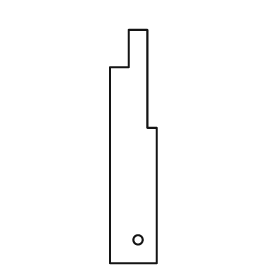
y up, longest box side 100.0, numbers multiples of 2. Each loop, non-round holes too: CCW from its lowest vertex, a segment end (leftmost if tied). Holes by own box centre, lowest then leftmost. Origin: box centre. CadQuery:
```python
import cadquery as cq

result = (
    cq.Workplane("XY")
    .moveTo(-10.0, -50.0)
    .lineTo(10.0, -50.0)
    .lineTo(10.0, 8.0)
    .lineTo(6.0, 8.0)
    .lineTo(6.0, 50.0)
    .lineTo(-2.0, 50.0)
    .lineTo(-2.0, 34.0)
    .lineTo(-10.0, 34.0)
    .close()
    .moveTo(2.0, -40.0)
    .circle(2.0)
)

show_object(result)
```